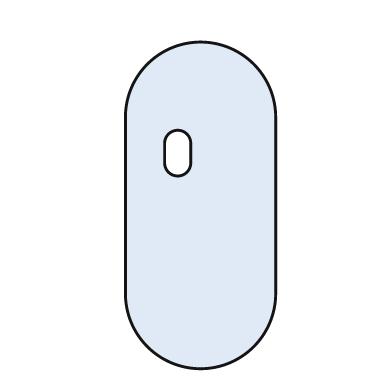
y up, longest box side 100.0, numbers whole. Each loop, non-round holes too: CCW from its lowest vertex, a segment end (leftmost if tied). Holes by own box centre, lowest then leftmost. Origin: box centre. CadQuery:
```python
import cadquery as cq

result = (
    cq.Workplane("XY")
    .moveTo(-23.0, -27.0)
    .threePointArc((0.0, -50.0), (23.0, -27.0))
    .lineTo(23.0, 27.0)
    .threePointArc((0.0, 50.0), (-23.0, 27.0))
    .close()
    .moveTo(-11.0, 13.0)
    .threePointArc((-7.0, 9.0), (-3.0, 13.0))
    .lineTo(-3.0, 19.0)
    .threePointArc((-7.0, 23.0), (-11.0, 19.0))
    .close()
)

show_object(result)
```